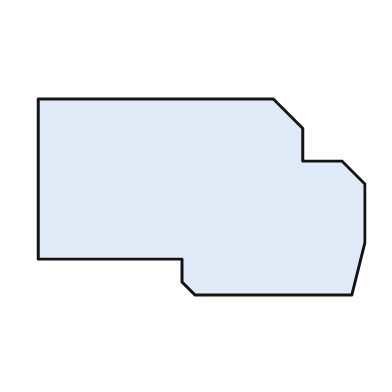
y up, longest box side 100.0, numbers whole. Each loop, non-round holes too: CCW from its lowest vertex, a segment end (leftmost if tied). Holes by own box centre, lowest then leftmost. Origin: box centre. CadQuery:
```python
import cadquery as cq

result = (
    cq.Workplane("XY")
    .moveTo(-2.0, -30.0)
    .lineTo(46.0, -30.0)
    .lineTo(50.0, -14.0)
    .lineTo(50.0, 4.0)
    .lineTo(43.0, 11.0)
    .lineTo(31.0, 11.0)
    .lineTo(31.0, 21.0)
    .lineTo(22.0, 30.0)
    .lineTo(-50.0, 30.0)
    .lineTo(-50.0, -19.0)
    .lineTo(-6.0, -19.0)
    .lineTo(-6.0, -26.0)
    .close()
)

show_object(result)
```